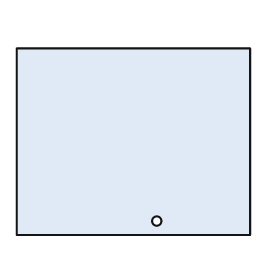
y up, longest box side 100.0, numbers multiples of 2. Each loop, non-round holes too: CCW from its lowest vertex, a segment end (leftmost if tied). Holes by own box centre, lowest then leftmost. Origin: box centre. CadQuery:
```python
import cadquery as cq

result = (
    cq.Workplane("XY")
    .moveTo(-50.0, -40.0)
    .lineTo(50.0, -40.0)
    .lineTo(50.0, 40.0)
    .lineTo(-50.0, 40.0)
    .close()
    .moveTo(10.0, -34.0)
    .circle(2.0)
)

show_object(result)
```